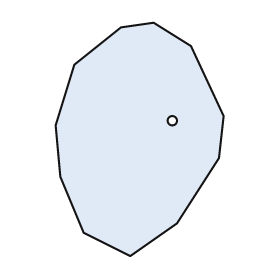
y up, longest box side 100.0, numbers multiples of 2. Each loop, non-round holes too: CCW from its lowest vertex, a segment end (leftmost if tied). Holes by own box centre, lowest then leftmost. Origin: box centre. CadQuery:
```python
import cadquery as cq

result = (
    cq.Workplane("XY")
    .moveTo(-4.0, -50.0)
    .lineTo(16.0, -36.0)
    .lineTo(34.0, -8.0)
    .lineTo(36.0, 10.0)
    .lineTo(22.0, 40.0)
    .lineTo(6.0, 50.0)
    .lineTo(-8.0, 48.0)
    .lineTo(-28.0, 32.0)
    .lineTo(-36.0, 6.0)
    .lineTo(-34.0, -16.0)
    .lineTo(-24.0, -40.0)
    .close()
    .moveTo(14.0, 8.0)
    .circle(2.0)
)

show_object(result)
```